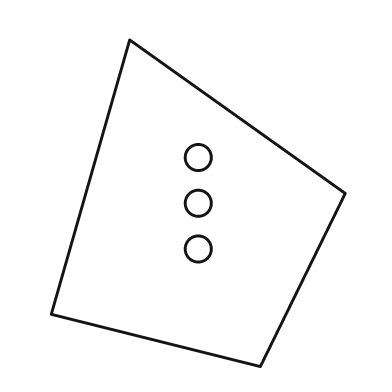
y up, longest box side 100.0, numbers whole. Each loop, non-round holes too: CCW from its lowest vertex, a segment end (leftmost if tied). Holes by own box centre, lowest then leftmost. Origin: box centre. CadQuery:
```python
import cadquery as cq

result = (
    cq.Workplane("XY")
    .moveTo(19.0, -50.0)
    .lineTo(45.0, 3.0)
    .lineTo(-21.0, 50.0)
    .lineTo(-45.0, -34.0)
    .close()
    .moveTo(0.0, -14.0)
    .circle(4.0)
    .moveTo(0.0, 0.0)
    .circle(4.0)
    .moveTo(0.0, 14.0)
    .circle(4.0)
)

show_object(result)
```